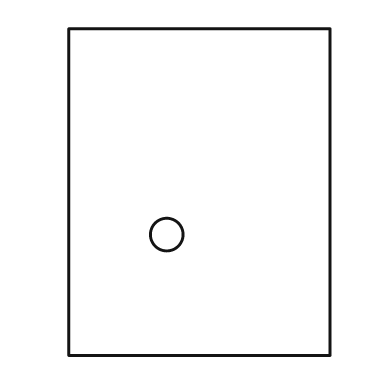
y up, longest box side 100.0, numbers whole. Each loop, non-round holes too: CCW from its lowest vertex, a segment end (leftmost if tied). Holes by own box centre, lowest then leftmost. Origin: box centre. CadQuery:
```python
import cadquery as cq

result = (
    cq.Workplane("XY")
    .moveTo(-40.0, -50.0)
    .lineTo(40.0, -50.0)
    .lineTo(40.0, 50.0)
    .lineTo(-40.0, 50.0)
    .close()
    .moveTo(-10.0, -13.0)
    .circle(5.0)
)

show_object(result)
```